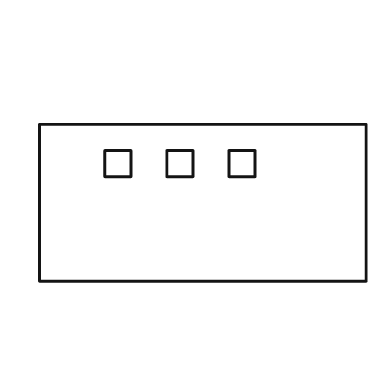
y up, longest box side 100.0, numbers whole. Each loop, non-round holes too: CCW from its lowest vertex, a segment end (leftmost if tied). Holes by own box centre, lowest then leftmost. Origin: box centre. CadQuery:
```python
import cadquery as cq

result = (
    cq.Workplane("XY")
    .moveTo(-50.0, -24.0)
    .lineTo(50.0, -24.0)
    .lineTo(50.0, 24.0)
    .lineTo(-50.0, 24.0)
    .close()
    .moveTo(-30.0, 8.0)
    .lineTo(-22.0, 8.0)
    .lineTo(-22.0, 16.0)
    .lineTo(-30.0, 16.0)
    .close()
    .moveTo(-11.0, 8.0)
    .lineTo(-3.0, 8.0)
    .lineTo(-3.0, 16.0)
    .lineTo(-11.0, 16.0)
    .close()
    .moveTo(8.0, 8.0)
    .lineTo(16.0, 8.0)
    .lineTo(16.0, 16.0)
    .lineTo(8.0, 16.0)
    .close()
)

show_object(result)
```